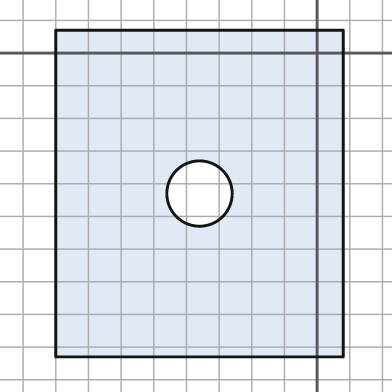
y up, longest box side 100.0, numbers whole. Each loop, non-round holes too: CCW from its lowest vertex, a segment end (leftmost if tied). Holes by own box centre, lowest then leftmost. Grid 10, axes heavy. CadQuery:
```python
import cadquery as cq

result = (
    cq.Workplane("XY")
    .moveTo(-80.0, -93.0)
    .lineTo(8.0, -93.0)
    .lineTo(8.0, 7.0)
    .lineTo(-80.0, 7.0)
    .close()
    .moveTo(-36.0, -43.0)
    .circle(10.0)
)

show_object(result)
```